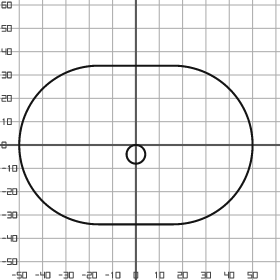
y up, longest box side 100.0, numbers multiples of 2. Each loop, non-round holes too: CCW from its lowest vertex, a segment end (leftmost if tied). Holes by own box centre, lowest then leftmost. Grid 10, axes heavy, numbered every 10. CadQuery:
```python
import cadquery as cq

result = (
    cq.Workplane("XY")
    .moveTo(-16.0, -34.0)
    .lineTo(16.0, -34.0)
    .threePointArc((50.0, 0.0), (16.0, 34.0))
    .lineTo(-16.0, 34.0)
    .threePointArc((-50.0, 0.0), (-16.0, -34.0))
    .close()
    .moveTo(0.0, -4.0)
    .circle(4.0)
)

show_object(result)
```